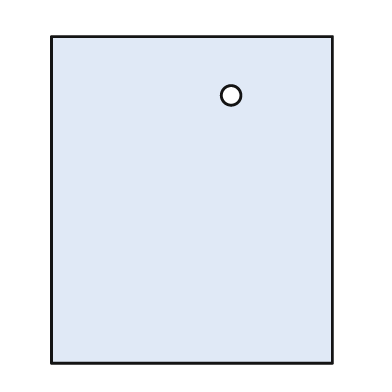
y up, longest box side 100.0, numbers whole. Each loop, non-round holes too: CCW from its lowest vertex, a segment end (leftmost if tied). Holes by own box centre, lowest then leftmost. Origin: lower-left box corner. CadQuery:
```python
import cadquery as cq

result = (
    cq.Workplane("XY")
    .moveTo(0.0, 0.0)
    .lineTo(86.0, 0.0)
    .lineTo(86.0, 100.0)
    .lineTo(0.0, 100.0)
    .close()
    .moveTo(55.0, 82.0)
    .circle(3.0)
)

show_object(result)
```